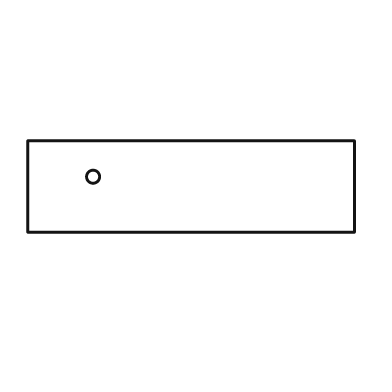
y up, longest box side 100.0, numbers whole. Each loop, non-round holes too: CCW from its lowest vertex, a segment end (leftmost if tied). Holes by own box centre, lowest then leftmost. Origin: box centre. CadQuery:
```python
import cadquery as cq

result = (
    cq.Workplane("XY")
    .moveTo(-50.0, -14.0)
    .lineTo(50.0, -14.0)
    .lineTo(50.0, 14.0)
    .lineTo(-50.0, 14.0)
    .close()
    .moveTo(-30.0, 3.0)
    .circle(2.0)
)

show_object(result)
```